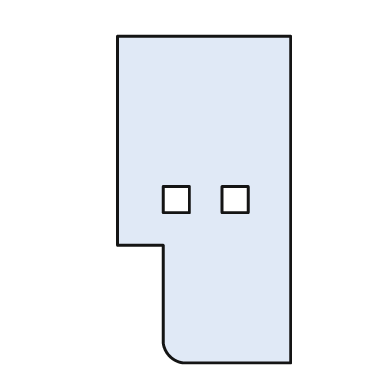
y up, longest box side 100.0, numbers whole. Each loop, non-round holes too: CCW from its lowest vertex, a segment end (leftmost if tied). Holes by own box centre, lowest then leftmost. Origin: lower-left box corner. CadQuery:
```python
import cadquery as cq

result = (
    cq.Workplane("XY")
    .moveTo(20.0, 0.0)
    .lineTo(53.0, 0.0)
    .lineTo(53.0, 100.0)
    .lineTo(0.0, 100.0)
    .lineTo(0.0, 36.0)
    .lineTo(14.0, 36.0)
    .lineTo(14.0, 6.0)
    .threePointArc((16.0, 2.0), (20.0, 0.0))
    .close()
    .moveTo(14.0, 46.0)
    .lineTo(22.0, 46.0)
    .lineTo(22.0, 54.0)
    .lineTo(14.0, 54.0)
    .close()
    .moveTo(32.0, 46.0)
    .lineTo(40.0, 46.0)
    .lineTo(40.0, 54.0)
    .lineTo(32.0, 54.0)
    .close()
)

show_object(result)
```